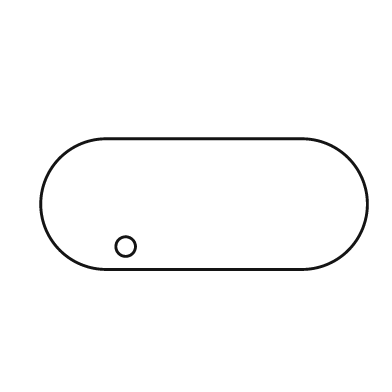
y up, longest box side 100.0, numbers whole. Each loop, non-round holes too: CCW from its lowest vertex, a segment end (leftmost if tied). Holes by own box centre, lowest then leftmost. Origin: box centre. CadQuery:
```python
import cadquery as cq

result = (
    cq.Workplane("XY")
    .moveTo(-30.0, -20.0)
    .lineTo(30.0, -20.0)
    .threePointArc((50.0, 0.0), (30.0, 20.0))
    .lineTo(-30.0, 20.0)
    .threePointArc((-50.0, 0.0), (-30.0, -20.0))
    .close()
    .moveTo(-24.0, -13.0)
    .circle(3.0)
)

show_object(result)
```